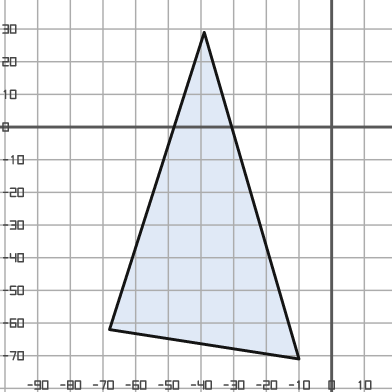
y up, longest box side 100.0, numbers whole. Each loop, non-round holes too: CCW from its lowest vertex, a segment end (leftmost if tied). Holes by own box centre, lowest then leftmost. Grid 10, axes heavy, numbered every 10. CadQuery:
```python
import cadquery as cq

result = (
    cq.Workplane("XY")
    .moveTo(-10.0, -71.0)
    .lineTo(-39.0, 29.0)
    .lineTo(-68.0, -62.0)
    .close()
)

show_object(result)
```